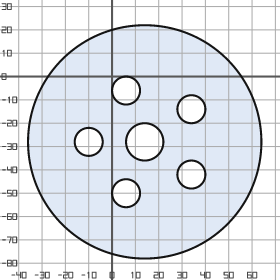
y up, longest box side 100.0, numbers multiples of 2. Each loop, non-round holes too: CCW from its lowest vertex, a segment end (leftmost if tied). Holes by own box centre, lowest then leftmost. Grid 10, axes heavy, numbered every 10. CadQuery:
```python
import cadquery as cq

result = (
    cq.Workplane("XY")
    .moveTo(14.0, -28.0)
    .circle(50.0)
    .moveTo(6.0, -50.0)
    .circle(6.0)
    .moveTo(34.0, -42.0)
    .circle(6.0)
    .moveTo(-10.0, -28.0)
    .circle(6.0)
    .moveTo(14.0, -28.0)
    .circle(8.0)
    .moveTo(34.0, -14.0)
    .circle(6.0)
    .moveTo(6.0, -6.0)
    .circle(6.0)
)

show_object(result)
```